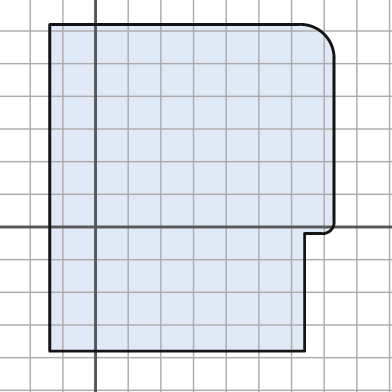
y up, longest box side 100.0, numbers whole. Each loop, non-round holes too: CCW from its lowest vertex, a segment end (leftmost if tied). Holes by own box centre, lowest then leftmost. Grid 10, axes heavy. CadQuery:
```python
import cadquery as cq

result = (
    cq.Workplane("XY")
    .moveTo(-14.0, -38.0)
    .lineTo(64.0, -38.0)
    .lineTo(64.0, -2.0)
    .lineTo(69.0, -2.0)
    .threePointArc((72.0, -1.0), (73.0, 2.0))
    .lineTo(73.0, 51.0)
    .threePointArc((70.0, 59.0), (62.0, 62.0))
    .lineTo(-14.0, 62.0)
    .close()
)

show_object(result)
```